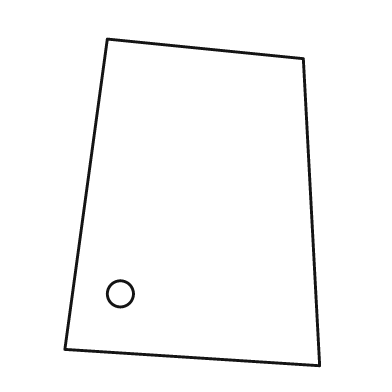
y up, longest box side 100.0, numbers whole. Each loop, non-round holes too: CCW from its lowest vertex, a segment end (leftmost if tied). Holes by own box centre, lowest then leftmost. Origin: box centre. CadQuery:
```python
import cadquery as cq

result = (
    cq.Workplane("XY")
    .moveTo(39.0, -50.0)
    .lineTo(34.0, 44.0)
    .lineTo(-26.0, 50.0)
    .lineTo(-39.0, -45.0)
    .close()
    .moveTo(-22.0, -28.0)
    .circle(4.0)
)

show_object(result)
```